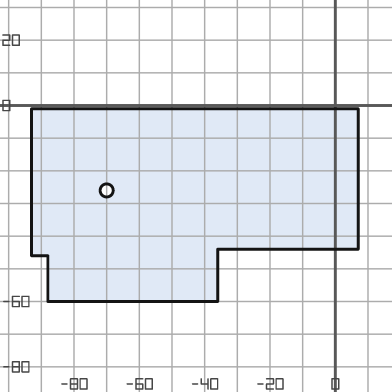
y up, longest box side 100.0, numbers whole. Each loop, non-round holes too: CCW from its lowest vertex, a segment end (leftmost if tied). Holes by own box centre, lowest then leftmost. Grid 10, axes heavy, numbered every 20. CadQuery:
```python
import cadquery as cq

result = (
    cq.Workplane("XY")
    .moveTo(-88.0, -60.0)
    .lineTo(-36.0, -60.0)
    .lineTo(-36.0, -44.0)
    .lineTo(7.0, -44.0)
    .lineTo(7.0, -1.0)
    .lineTo(-93.0, -1.0)
    .lineTo(-93.0, -46.0)
    .lineTo(-88.0, -46.0)
    .close()
    .moveTo(-70.0, -26.0)
    .circle(2.0)
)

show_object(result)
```